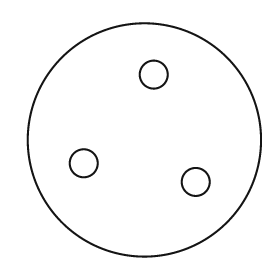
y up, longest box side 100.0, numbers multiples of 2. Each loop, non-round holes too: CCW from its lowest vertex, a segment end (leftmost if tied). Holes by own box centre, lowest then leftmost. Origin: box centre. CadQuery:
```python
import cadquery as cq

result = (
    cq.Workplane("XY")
    .moveTo(0.0, 0.0)
    .circle(50.0)
    .moveTo(22.0, -18.0)
    .circle(6.0)
    .moveTo(-26.0, -10.0)
    .circle(6.0)
    .moveTo(4.0, 28.0)
    .circle(6.0)
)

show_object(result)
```